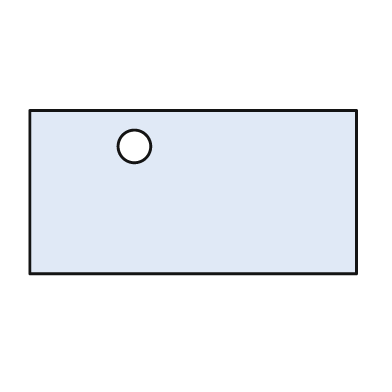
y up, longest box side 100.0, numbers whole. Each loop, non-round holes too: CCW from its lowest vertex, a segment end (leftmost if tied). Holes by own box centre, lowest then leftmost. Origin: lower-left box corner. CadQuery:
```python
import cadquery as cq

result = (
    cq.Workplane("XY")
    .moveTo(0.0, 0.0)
    .lineTo(100.0, 0.0)
    .lineTo(100.0, 50.0)
    .lineTo(0.0, 50.0)
    .close()
    .moveTo(32.0, 39.0)
    .circle(5.0)
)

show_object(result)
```